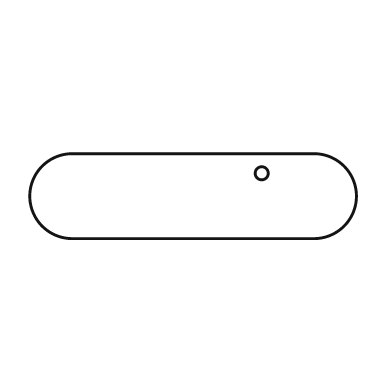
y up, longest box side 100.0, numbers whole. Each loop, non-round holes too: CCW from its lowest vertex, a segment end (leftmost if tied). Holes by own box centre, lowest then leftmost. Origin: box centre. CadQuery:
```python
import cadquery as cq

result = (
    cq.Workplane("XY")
    .moveTo(-37.0, -13.0)
    .lineTo(37.0, -13.0)
    .threePointArc((50.0, 0.0), (37.0, 13.0))
    .lineTo(-37.0, 13.0)
    .threePointArc((-50.0, 0.0), (-37.0, -13.0))
    .close()
    .moveTo(21.0, 7.0)
    .circle(2.0)
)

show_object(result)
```